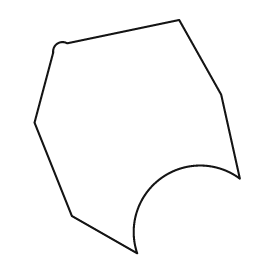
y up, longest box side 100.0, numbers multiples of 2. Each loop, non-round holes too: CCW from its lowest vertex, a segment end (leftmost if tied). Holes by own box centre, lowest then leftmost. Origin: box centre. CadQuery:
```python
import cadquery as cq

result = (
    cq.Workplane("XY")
    .moveTo(0.0, -50.0)
    .threePointArc((10.0, -18.0), (44.0, -18.0))
    .lineTo(36.0, 18.0)
    .lineTo(18.0, 50.0)
    .lineTo(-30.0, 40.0)
    .threePointArc((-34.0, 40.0), (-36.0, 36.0))
    .lineTo(-44.0, 6.0)
    .lineTo(-28.0, -34.0)
    .close()
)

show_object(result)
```